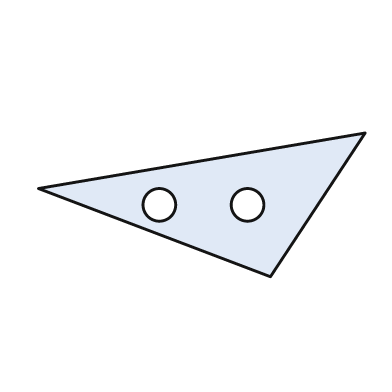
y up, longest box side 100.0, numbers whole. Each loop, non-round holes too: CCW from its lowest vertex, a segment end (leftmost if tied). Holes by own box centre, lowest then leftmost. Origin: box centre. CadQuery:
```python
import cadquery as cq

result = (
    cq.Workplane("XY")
    .moveTo(21.0, -22.0)
    .lineTo(50.0, 22.0)
    .lineTo(-50.0, 5.0)
    .close()
    .moveTo(-13.0, 0.0)
    .circle(5.0)
    .moveTo(14.0, 0.0)
    .circle(5.0)
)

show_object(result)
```